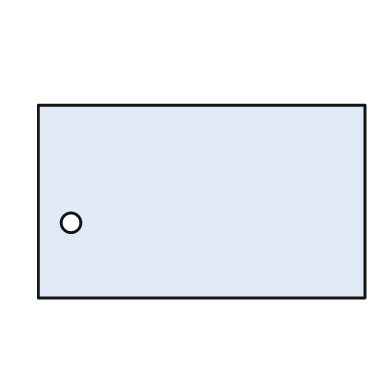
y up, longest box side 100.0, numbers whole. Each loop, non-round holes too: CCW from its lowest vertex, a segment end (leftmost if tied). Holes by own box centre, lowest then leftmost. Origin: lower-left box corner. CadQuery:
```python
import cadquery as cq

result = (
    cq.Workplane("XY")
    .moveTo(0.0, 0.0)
    .lineTo(100.0, 0.0)
    .lineTo(100.0, 59.0)
    .lineTo(0.0, 59.0)
    .close()
    .moveTo(10.0, 23.0)
    .circle(3.0)
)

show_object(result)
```